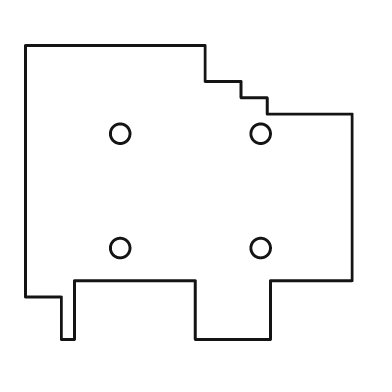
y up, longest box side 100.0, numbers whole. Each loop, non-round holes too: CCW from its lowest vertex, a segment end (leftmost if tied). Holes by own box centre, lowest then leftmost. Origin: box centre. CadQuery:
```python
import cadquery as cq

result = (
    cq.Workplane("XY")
    .moveTo(-39.0, -45.0)
    .lineTo(-35.0, -45.0)
    .lineTo(-35.0, -27.0)
    .lineTo(2.0, -27.0)
    .lineTo(2.0, -45.0)
    .lineTo(25.0, -45.0)
    .lineTo(25.0, -27.0)
    .lineTo(50.0, -27.0)
    .lineTo(50.0, 24.0)
    .lineTo(24.0, 24.0)
    .lineTo(24.0, 29.0)
    .lineTo(16.0, 29.0)
    .lineTo(16.0, 34.0)
    .lineTo(5.0, 34.0)
    .lineTo(5.0, 45.0)
    .lineTo(-50.0, 45.0)
    .lineTo(-50.0, -32.0)
    .lineTo(-39.0, -32.0)
    .close()
    .moveTo(-21.0, -17.0)
    .circle(3.0)
    .moveTo(22.0, -17.0)
    .circle(3.0)
    .moveTo(-21.0, 18.0)
    .circle(3.0)
    .moveTo(22.0, 18.0)
    .circle(3.0)
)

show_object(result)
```